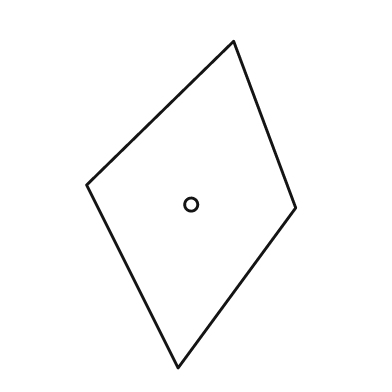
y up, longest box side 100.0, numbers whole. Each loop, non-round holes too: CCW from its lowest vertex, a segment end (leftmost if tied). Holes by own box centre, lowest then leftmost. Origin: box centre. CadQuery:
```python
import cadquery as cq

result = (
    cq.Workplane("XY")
    .moveTo(-4.0, -50.0)
    .lineTo(32.0, -1.0)
    .lineTo(13.0, 50.0)
    .lineTo(-32.0, 6.0)
    .close()
    .moveTo(0.0, 0.0)
    .circle(2.0)
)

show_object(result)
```